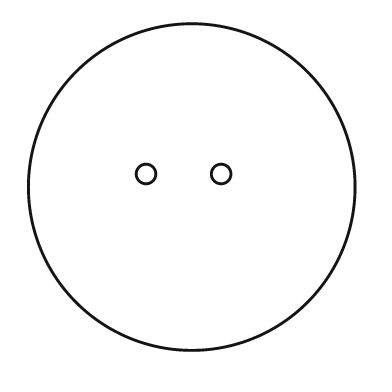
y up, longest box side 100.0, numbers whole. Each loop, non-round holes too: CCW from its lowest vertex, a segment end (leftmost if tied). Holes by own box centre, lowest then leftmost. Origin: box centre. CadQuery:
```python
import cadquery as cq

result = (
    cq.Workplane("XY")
    .moveTo(0.0, 0.0)
    .circle(50.0)
    .moveTo(-14.0, 4.0)
    .circle(3.0)
    .moveTo(9.0, 4.0)
    .circle(3.0)
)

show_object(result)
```